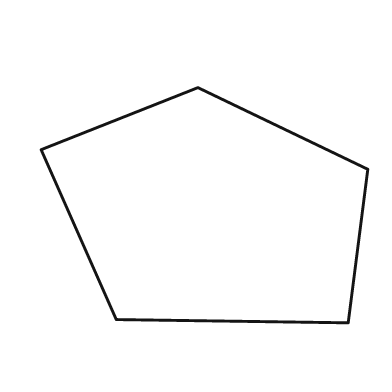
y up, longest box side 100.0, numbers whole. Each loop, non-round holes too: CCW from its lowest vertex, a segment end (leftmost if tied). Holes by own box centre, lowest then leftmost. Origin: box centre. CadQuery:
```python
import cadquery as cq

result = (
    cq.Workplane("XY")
    .moveTo(44.0, -36.0)
    .lineTo(50.0, 11.0)
    .lineTo(-2.0, 36.0)
    .lineTo(-50.0, 17.0)
    .lineTo(-27.0, -35.0)
    .close()
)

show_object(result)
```